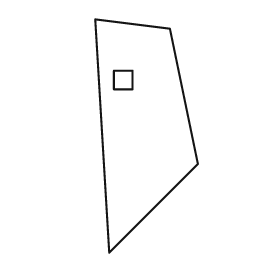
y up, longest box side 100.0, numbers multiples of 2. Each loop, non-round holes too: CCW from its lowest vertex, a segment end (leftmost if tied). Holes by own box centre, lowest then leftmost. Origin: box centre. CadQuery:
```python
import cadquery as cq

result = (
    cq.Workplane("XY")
    .moveTo(-16.0, -50.0)
    .lineTo(22.0, -12.0)
    .lineTo(10.0, 46.0)
    .lineTo(-22.0, 50.0)
    .close()
    .moveTo(-14.0, 20.0)
    .lineTo(-6.0, 20.0)
    .lineTo(-6.0, 28.0)
    .lineTo(-14.0, 28.0)
    .close()
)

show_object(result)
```